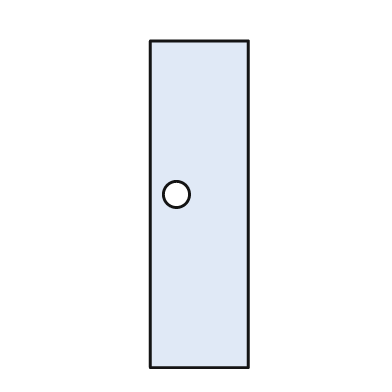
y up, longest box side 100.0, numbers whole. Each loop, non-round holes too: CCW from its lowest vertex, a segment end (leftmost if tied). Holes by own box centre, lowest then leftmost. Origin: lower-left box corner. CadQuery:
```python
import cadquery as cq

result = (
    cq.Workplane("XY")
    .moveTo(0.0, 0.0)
    .lineTo(30.0, 0.0)
    .lineTo(30.0, 100.0)
    .lineTo(0.0, 100.0)
    .close()
    .moveTo(8.0, 53.0)
    .circle(4.0)
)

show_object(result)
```